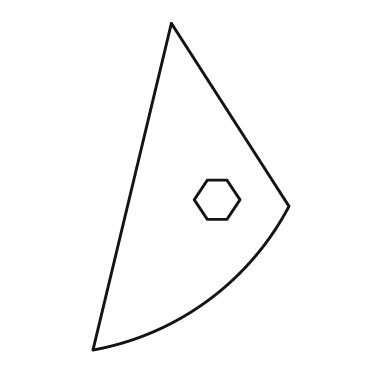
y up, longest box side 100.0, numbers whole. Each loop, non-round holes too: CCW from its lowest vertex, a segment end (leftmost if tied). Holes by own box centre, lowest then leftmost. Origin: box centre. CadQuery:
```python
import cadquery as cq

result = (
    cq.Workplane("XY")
    .moveTo(-30.0, -50.0)
    .threePointArc((5.0, -35.0), (30.0, -6.0))
    .lineTo(-6.0, 50.0)
    .close()
    .moveTo(5.0, -10.0)
    .lineTo(11.0, -10.0)
    .lineTo(15.0, -4.0)
    .lineTo(11.0, 2.0)
    .lineTo(5.0, 2.0)
    .lineTo(1.0, -4.0)
    .close()
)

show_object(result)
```